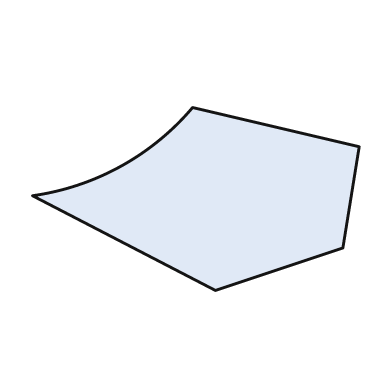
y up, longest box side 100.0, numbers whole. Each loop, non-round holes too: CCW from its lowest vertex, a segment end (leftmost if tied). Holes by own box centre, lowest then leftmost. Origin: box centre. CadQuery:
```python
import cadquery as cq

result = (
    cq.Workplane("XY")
    .moveTo(6.0, -28.0)
    .lineTo(45.0, -15.0)
    .lineTo(50.0, 16.0)
    .lineTo(-1.0, 28.0)
    .threePointArc((-23.0, 10.0), (-50.0, 1.0))
    .close()
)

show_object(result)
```